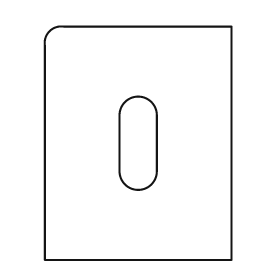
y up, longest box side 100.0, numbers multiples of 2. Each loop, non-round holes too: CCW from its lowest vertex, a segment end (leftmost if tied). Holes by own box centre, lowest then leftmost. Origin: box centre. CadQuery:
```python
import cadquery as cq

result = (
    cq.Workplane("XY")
    .moveTo(-40.0, -50.0)
    .lineTo(40.0, -50.0)
    .lineTo(40.0, 50.0)
    .lineTo(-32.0, 50.0)
    .threePointArc((-38.0, 48.0), (-40.0, 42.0))
    .close()
    .moveTo(-8.0, -12.0)
    .threePointArc((0.0, -20.0), (8.0, -12.0))
    .lineTo(8.0, 12.0)
    .threePointArc((0.0, 20.0), (-8.0, 12.0))
    .close()
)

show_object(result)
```